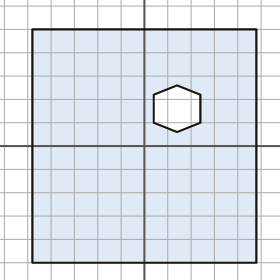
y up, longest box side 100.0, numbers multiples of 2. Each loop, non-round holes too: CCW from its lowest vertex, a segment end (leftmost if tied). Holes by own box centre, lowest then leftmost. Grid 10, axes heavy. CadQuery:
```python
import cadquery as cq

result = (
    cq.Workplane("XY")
    .moveTo(-48.0, -50.0)
    .lineTo(48.0, -50.0)
    .lineTo(48.0, 50.0)
    .lineTo(-48.0, 50.0)
    .close()
    .moveTo(14.0, 6.0)
    .lineTo(24.0, 10.0)
    .lineTo(24.0, 22.0)
    .lineTo(14.0, 26.0)
    .lineTo(4.0, 22.0)
    .lineTo(4.0, 10.0)
    .close()
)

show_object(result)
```